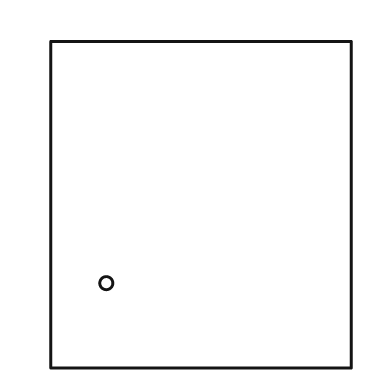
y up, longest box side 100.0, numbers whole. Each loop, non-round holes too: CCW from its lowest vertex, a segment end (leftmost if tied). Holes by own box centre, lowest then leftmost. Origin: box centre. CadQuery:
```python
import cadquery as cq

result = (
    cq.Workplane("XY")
    .moveTo(-46.0, -50.0)
    .lineTo(46.0, -50.0)
    .lineTo(46.0, 50.0)
    .lineTo(-46.0, 50.0)
    .close()
    .moveTo(-29.0, -24.0)
    .circle(2.0)
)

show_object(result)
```